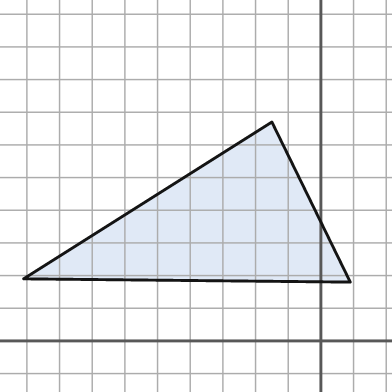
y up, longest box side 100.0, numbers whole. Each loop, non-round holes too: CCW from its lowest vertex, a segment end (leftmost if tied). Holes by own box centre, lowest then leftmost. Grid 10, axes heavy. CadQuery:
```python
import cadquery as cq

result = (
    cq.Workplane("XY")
    .moveTo(9.0, 18.0)
    .lineTo(-15.0, 67.0)
    .lineTo(-91.0, 19.0)
    .close()
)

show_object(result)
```